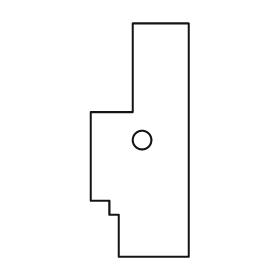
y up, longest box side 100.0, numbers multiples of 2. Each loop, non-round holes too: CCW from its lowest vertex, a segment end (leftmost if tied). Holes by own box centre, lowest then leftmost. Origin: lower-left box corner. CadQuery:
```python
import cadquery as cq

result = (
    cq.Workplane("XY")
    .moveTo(12.0, 0.0)
    .lineTo(42.0, 0.0)
    .lineTo(42.0, 100.0)
    .lineTo(18.0, 100.0)
    .lineTo(18.0, 62.0)
    .lineTo(0.0, 62.0)
    .lineTo(0.0, 24.0)
    .lineTo(8.0, 24.0)
    .lineTo(8.0, 18.0)
    .lineTo(12.0, 18.0)
    .close()
    .moveTo(22.0, 50.0)
    .circle(4.0)
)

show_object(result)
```